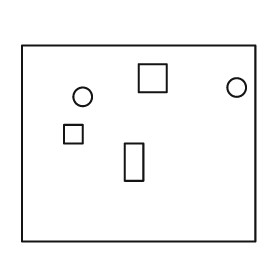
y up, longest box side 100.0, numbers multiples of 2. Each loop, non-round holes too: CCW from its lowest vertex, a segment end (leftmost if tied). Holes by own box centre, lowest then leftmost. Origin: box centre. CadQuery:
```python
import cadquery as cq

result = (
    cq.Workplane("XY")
    .moveTo(-50.0, -42.0)
    .lineTo(50.0, -42.0)
    .lineTo(50.0, 42.0)
    .lineTo(-50.0, 42.0)
    .close()
    .moveTo(-6.0, -16.0)
    .lineTo(2.0, -16.0)
    .lineTo(2.0, 0.0)
    .lineTo(-6.0, 0.0)
    .close()
    .moveTo(-32.0, 0.0)
    .lineTo(-24.0, 0.0)
    .lineTo(-24.0, 8.0)
    .lineTo(-32.0, 8.0)
    .close()
    .moveTo(-24.0, 20.0)
    .circle(4.0)
    .moveTo(42.0, 24.0)
    .circle(4.0)
    .moveTo(0.0, 22.0)
    .lineTo(12.0, 22.0)
    .lineTo(12.0, 34.0)
    .lineTo(0.0, 34.0)
    .close()
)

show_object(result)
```